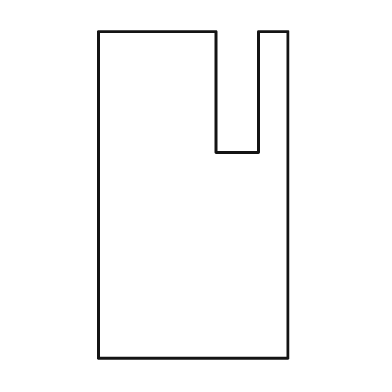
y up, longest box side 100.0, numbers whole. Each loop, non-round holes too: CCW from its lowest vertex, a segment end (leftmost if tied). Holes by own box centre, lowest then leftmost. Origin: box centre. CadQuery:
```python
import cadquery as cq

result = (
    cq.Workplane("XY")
    .moveTo(-29.0, -50.0)
    .lineTo(29.0, -50.0)
    .lineTo(29.0, 50.0)
    .lineTo(20.0, 50.0)
    .lineTo(20.0, 13.0)
    .lineTo(7.0, 13.0)
    .lineTo(7.0, 50.0)
    .lineTo(-29.0, 50.0)
    .close()
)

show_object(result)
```